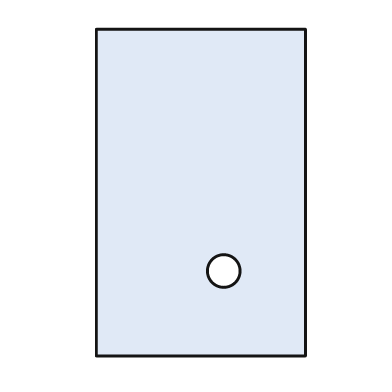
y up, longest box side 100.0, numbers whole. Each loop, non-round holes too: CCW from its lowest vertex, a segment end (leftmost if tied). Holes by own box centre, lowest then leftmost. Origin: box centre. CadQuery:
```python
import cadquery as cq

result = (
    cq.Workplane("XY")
    .moveTo(-32.0, -50.0)
    .lineTo(32.0, -50.0)
    .lineTo(32.0, 50.0)
    .lineTo(-32.0, 50.0)
    .close()
    .moveTo(7.0, -24.0)
    .circle(5.0)
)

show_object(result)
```